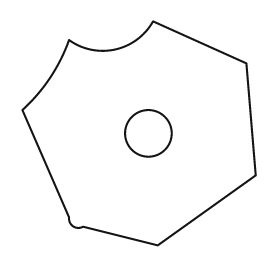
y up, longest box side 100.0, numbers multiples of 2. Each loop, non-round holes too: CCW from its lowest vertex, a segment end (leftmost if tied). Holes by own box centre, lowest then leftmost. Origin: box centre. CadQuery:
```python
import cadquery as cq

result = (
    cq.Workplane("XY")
    .moveTo(8.0, -48.0)
    .lineTo(50.0, -18.0)
    .lineTo(46.0, 30.0)
    .lineTo(6.0, 48.0)
    .threePointArc((-10.0, 36.0), (-30.0, 40.0))
    .threePointArc((-38.0, 24.0), (-50.0, 10.0))
    .lineTo(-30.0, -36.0)
    .threePointArc((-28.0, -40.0), (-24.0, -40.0))
    .close()
    .moveTo(4.0, 0.0)
    .circle(10.0)
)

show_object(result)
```